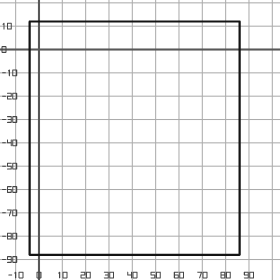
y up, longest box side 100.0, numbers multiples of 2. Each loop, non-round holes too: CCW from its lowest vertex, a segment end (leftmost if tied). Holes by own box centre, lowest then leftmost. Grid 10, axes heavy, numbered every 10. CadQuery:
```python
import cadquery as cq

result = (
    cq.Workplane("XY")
    .moveTo(-4.0, -88.0)
    .lineTo(86.0, -88.0)
    .lineTo(86.0, 12.0)
    .lineTo(-4.0, 12.0)
    .close()
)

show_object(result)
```